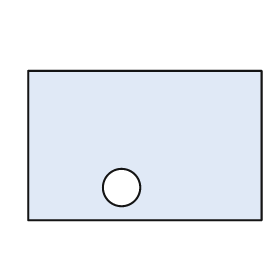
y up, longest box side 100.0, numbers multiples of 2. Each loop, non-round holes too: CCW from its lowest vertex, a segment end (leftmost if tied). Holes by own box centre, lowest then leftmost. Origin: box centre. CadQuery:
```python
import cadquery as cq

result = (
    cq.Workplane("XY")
    .moveTo(-50.0, -32.0)
    .lineTo(50.0, -32.0)
    .lineTo(50.0, 32.0)
    .lineTo(-50.0, 32.0)
    .close()
    .moveTo(-10.0, -18.0)
    .circle(8.0)
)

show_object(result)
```